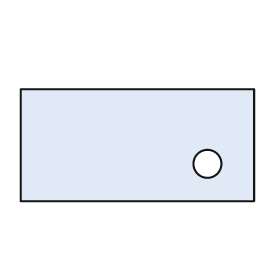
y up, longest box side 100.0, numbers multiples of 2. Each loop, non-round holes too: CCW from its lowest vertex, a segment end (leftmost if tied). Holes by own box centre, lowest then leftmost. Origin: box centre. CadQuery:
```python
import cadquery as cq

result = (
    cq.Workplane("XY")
    .moveTo(-50.0, -24.0)
    .lineTo(50.0, -24.0)
    .lineTo(50.0, 24.0)
    .lineTo(-50.0, 24.0)
    .close()
    .moveTo(30.0, -8.0)
    .circle(6.0)
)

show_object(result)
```